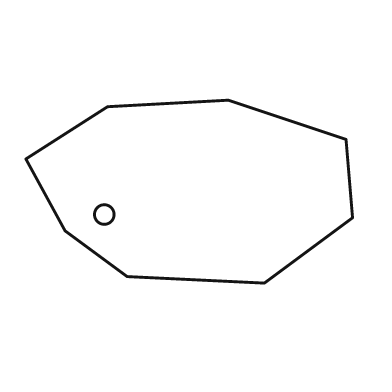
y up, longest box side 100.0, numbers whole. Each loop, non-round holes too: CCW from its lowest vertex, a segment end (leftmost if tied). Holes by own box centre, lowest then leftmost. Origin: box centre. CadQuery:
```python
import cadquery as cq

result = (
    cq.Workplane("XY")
    .moveTo(23.0, -28.0)
    .lineTo(50.0, -8.0)
    .lineTo(48.0, 16.0)
    .lineTo(12.0, 28.0)
    .lineTo(-25.0, 26.0)
    .lineTo(-50.0, 10.0)
    .lineTo(-38.0, -12.0)
    .lineTo(-19.0, -26.0)
    .close()
    .moveTo(-26.0, -7.0)
    .circle(3.0)
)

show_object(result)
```